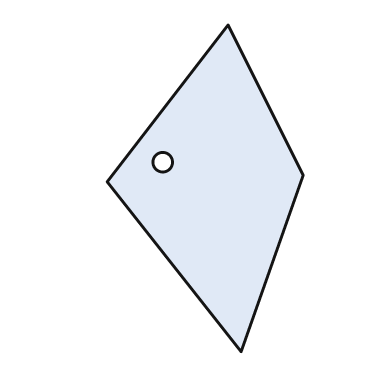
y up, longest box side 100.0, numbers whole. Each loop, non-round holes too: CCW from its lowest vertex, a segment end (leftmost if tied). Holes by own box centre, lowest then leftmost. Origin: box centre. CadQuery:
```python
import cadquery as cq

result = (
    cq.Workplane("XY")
    .moveTo(11.0, -50.0)
    .lineTo(30.0, 4.0)
    .lineTo(7.0, 50.0)
    .lineTo(-30.0, 2.0)
    .close()
    .moveTo(-13.0, 8.0)
    .circle(3.0)
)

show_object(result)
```